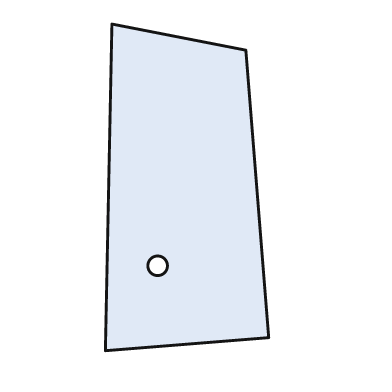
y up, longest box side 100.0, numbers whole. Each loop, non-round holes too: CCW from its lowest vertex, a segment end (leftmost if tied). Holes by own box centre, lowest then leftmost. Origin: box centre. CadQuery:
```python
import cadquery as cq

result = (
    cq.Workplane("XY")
    .moveTo(-25.0, -50.0)
    .lineTo(25.0, -46.0)
    .lineTo(18.0, 42.0)
    .lineTo(-23.0, 50.0)
    .close()
    .moveTo(-9.0, -24.0)
    .circle(3.0)
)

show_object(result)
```